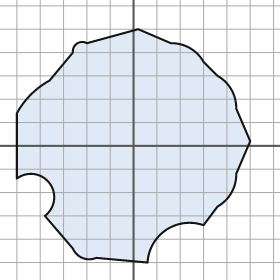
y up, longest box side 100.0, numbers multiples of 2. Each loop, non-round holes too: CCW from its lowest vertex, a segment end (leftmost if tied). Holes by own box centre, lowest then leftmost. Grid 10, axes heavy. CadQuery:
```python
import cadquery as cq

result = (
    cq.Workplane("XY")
    .moveTo(6.0, -50.0)
    .threePointArc((14.0, -36.0), (30.0, -34.0))
    .lineTo(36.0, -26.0)
    .threePointArc((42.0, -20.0), (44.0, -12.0))
    .lineTo(50.0, 2.0)
    .lineTo(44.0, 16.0)
    .threePointArc((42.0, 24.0), (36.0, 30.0))
    .lineTo(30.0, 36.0)
    .threePointArc((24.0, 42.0), (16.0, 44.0))
    .lineTo(2.0, 50.0)
    .lineTo(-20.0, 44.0)
    .threePointArc((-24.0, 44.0), (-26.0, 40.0))
    .lineTo(-36.0, 28.0)
    .threePointArc((-44.0, 22.0), (-50.0, 14.0))
    .lineTo(-50.0, -14.0)
    .threePointArc((-36.0, -16.0), (-38.0, -30.0))
    .lineTo(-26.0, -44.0)
    .threePointArc((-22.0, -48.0), (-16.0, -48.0))
    .close()
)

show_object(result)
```